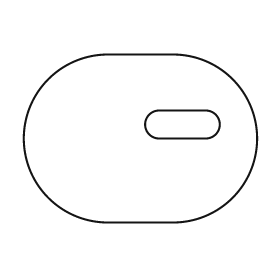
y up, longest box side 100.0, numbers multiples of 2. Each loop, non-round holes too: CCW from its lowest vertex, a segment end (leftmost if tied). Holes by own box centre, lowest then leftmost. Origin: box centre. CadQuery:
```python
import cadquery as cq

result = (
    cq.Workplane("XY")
    .moveTo(-14.0, -36.0)
    .lineTo(14.0, -36.0)
    .threePointArc((50.0, 0.0), (14.0, 36.0))
    .lineTo(-14.0, 36.0)
    .threePointArc((-50.0, 0.0), (-14.0, -36.0))
    .close()
    .moveTo(8.0, 0.0)
    .lineTo(28.0, 0.0)
    .threePointArc((34.0, 6.0), (28.0, 12.0))
    .lineTo(8.0, 12.0)
    .threePointArc((2.0, 6.0), (8.0, 0.0))
    .close()
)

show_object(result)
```